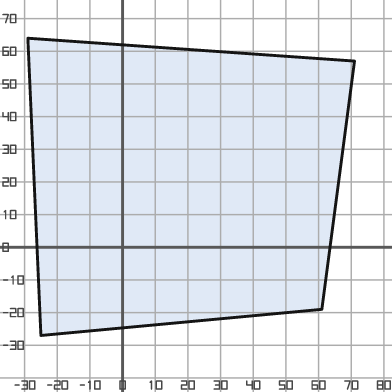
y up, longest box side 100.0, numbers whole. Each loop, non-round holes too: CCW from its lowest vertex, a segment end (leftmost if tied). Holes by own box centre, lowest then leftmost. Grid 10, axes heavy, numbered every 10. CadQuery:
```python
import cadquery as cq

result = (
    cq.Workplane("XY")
    .moveTo(-25.0, -27.0)
    .lineTo(61.0, -19.0)
    .lineTo(71.0, 57.0)
    .lineTo(-29.0, 64.0)
    .close()
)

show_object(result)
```